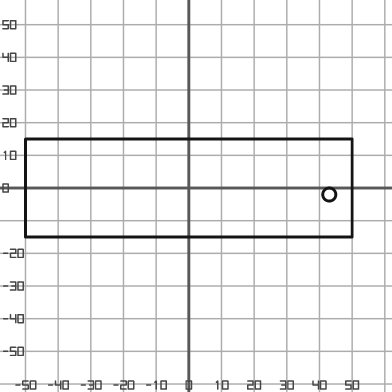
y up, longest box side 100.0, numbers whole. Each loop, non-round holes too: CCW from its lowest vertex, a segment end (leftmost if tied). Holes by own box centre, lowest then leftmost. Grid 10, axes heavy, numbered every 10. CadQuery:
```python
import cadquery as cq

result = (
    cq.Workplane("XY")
    .moveTo(-50.0, -15.0)
    .lineTo(50.0, -15.0)
    .lineTo(50.0, 15.0)
    .lineTo(-50.0, 15.0)
    .close()
    .moveTo(43.0, -2.0)
    .circle(2.0)
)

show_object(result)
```